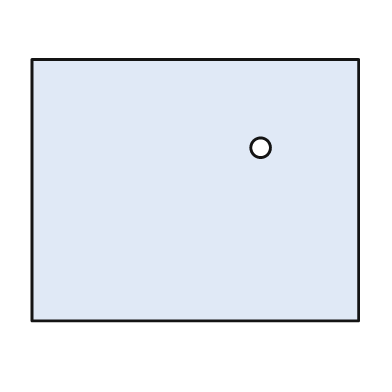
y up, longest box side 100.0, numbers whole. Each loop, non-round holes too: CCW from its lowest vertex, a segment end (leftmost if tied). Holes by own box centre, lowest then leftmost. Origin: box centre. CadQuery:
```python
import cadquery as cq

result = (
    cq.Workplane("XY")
    .moveTo(-50.0, -40.0)
    .lineTo(50.0, -40.0)
    .lineTo(50.0, 40.0)
    .lineTo(-50.0, 40.0)
    .close()
    .moveTo(20.0, 13.0)
    .circle(3.0)
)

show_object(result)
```